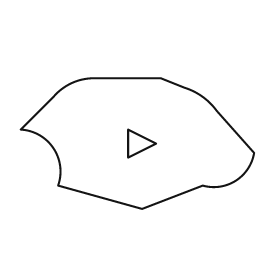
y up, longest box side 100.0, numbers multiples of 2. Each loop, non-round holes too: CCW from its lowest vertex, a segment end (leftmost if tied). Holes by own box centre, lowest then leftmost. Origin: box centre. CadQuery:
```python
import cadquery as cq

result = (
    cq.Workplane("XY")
    .moveTo(2.0, -28.0)
    .lineTo(28.0, -18.0)
    .threePointArc((42.0, -16.0), (50.0, -4.0))
    .lineTo(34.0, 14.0)
    .threePointArc((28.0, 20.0), (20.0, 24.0))
    .lineTo(10.0, 28.0)
    .lineTo(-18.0, 28.0)
    .threePointArc((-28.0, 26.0), (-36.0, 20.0))
    .lineTo(-50.0, 6.0)
    .threePointArc((-36.0, -2.0), (-34.0, -18.0))
    .close()
    .moveTo(-4.0, -6.0)
    .lineTo(8.0, 0.0)
    .lineTo(-4.0, 6.0)
    .close()
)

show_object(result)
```